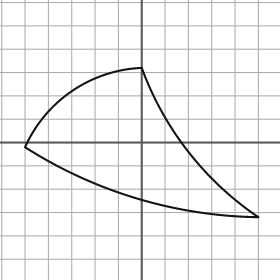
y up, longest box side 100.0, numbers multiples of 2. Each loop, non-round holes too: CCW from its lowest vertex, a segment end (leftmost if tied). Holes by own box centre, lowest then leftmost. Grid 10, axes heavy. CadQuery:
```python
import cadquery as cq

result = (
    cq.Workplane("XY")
    .moveTo(50.0, -32.0)
    .threePointArc((20.0, -4.0), (0.0, 32.0))
    .threePointArc((-30.0, 22.0), (-50.0, -2.0))
    .threePointArc((-2.0, -24.0), (50.0, -32.0))
    .close()
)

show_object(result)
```